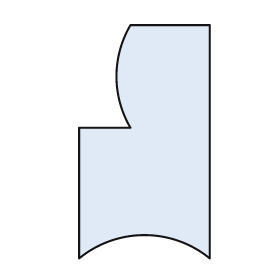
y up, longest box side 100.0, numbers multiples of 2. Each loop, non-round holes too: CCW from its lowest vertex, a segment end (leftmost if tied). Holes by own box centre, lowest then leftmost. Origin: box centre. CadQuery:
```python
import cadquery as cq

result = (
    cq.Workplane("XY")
    .moveTo(-28.0, -50.0)
    .threePointArc((0.0, -40.0), (28.0, -50.0))
    .lineTo(28.0, 50.0)
    .lineTo(-6.0, 50.0)
    .threePointArc((-12.0, 28.0), (-6.0, 6.0))
    .lineTo(-28.0, 6.0)
    .close()
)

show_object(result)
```